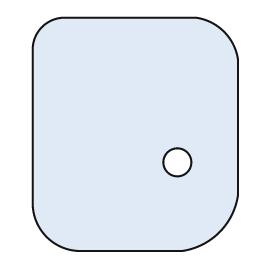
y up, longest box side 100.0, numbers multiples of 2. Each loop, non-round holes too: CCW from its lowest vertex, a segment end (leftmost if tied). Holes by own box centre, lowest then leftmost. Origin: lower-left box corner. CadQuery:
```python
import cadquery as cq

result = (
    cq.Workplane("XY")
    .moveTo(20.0, 0.0)
    .lineTo(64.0, 0.0)
    .threePointArc((80.0, 8.0), (88.0, 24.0))
    .lineTo(88.0, 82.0)
    .threePointArc((82.0, 94.0), (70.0, 100.0))
    .lineTo(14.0, 100.0)
    .threePointArc((4.0, 96.0), (0.0, 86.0))
    .lineTo(0.0, 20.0)
    .threePointArc((6.0, 6.0), (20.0, 0.0))
    .close()
    .moveTo(62.0, 38.0)
    .circle(6.0)
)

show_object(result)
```